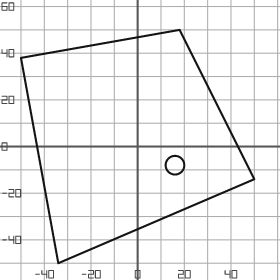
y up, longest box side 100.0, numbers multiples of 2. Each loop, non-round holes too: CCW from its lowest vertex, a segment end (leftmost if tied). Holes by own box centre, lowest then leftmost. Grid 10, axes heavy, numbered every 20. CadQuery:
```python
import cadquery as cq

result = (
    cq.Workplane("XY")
    .moveTo(-34.0, -50.0)
    .lineTo(50.0, -14.0)
    .lineTo(18.0, 50.0)
    .lineTo(-50.0, 38.0)
    .close()
    .moveTo(16.0, -8.0)
    .circle(4.0)
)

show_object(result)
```